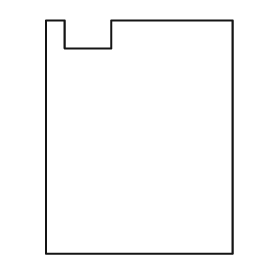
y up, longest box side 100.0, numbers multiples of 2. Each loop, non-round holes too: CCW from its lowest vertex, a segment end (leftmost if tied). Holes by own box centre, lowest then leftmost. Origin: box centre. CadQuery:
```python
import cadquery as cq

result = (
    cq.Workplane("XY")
    .moveTo(-40.0, -50.0)
    .lineTo(40.0, -50.0)
    .lineTo(40.0, 50.0)
    .lineTo(-12.0, 50.0)
    .lineTo(-12.0, 38.0)
    .lineTo(-32.0, 38.0)
    .lineTo(-32.0, 50.0)
    .lineTo(-40.0, 50.0)
    .close()
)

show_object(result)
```